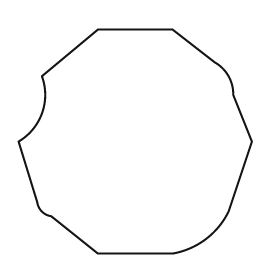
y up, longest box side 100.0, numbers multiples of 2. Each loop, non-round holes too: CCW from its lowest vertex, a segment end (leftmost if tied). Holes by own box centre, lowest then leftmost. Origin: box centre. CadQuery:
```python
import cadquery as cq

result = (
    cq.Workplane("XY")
    .moveTo(-16.0, -48.0)
    .lineTo(16.0, -48.0)
    .threePointArc((30.0, -42.0), (40.0, -30.0))
    .lineTo(50.0, 0.0)
    .lineTo(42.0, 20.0)
    .threePointArc((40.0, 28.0), (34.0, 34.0))
    .lineTo(16.0, 48.0)
    .lineTo(-16.0, 48.0)
    .lineTo(-40.0, 28.0)
    .threePointArc((-40.0, 12.0), (-50.0, 0.0))
    .lineTo(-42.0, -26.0)
    .threePointArc((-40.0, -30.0), (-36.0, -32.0))
    .close()
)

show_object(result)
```